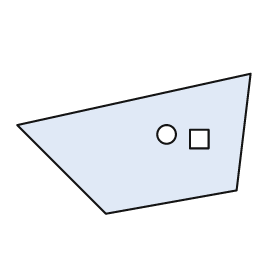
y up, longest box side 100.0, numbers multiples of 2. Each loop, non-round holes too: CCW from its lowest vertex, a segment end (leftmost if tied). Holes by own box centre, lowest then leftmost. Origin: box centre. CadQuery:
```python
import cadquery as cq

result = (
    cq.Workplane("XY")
    .moveTo(-12.0, -30.0)
    .lineTo(44.0, -20.0)
    .lineTo(50.0, 30.0)
    .lineTo(-50.0, 8.0)
    .close()
    .moveTo(24.0, -2.0)
    .lineTo(32.0, -2.0)
    .lineTo(32.0, 6.0)
    .lineTo(24.0, 6.0)
    .close()
    .moveTo(14.0, 4.0)
    .circle(4.0)
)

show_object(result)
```